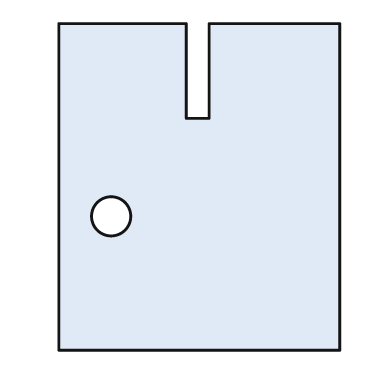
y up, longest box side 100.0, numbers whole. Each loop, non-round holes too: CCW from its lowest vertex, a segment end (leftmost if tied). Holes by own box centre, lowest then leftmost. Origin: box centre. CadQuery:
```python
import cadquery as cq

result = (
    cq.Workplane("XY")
    .moveTo(-43.0, -50.0)
    .lineTo(43.0, -50.0)
    .lineTo(43.0, 50.0)
    .lineTo(3.0, 50.0)
    .lineTo(3.0, 21.0)
    .lineTo(-4.0, 21.0)
    .lineTo(-4.0, 50.0)
    .lineTo(-43.0, 50.0)
    .close()
    .moveTo(-27.0, -9.0)
    .circle(6.0)
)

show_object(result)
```